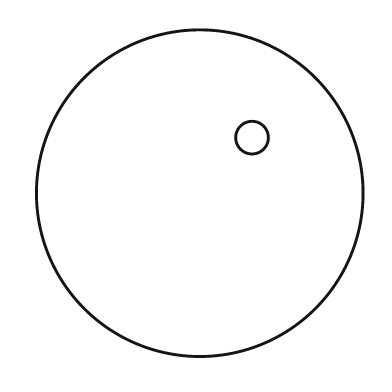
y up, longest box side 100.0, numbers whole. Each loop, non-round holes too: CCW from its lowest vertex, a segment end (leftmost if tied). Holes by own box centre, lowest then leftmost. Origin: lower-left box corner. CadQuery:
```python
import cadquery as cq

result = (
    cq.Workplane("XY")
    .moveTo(50.0, 50.0)
    .circle(50.0)
    .moveTo(66.0, 67.0)
    .circle(5.0)
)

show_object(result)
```